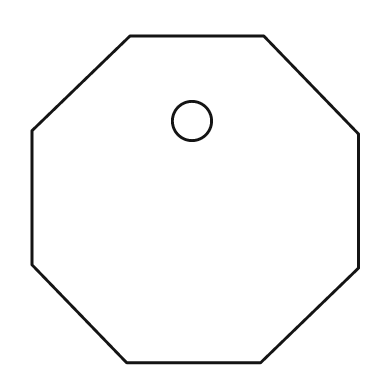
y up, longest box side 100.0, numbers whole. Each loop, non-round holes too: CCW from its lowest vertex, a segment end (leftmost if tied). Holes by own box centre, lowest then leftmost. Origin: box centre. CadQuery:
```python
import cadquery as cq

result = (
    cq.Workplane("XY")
    .moveTo(-21.0, -50.0)
    .lineTo(20.0, -50.0)
    .lineTo(50.0, -21.0)
    .lineTo(50.0, 20.0)
    .lineTo(21.0, 50.0)
    .lineTo(-20.0, 50.0)
    .lineTo(-50.0, 21.0)
    .lineTo(-50.0, -20.0)
    .close()
    .moveTo(-1.0, 24.0)
    .circle(6.0)
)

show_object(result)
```